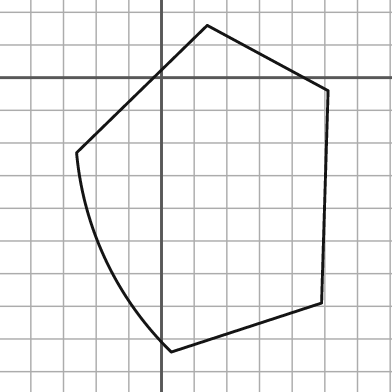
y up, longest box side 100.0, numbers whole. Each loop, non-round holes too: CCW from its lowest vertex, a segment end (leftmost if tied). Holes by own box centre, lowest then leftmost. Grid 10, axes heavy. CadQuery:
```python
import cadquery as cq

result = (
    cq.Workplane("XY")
    .moveTo(3.0, -84.0)
    .lineTo(49.0, -69.0)
    .lineTo(51.0, -4.0)
    .lineTo(14.0, 16.0)
    .lineTo(-26.0, -23.0)
    .threePointArc((-17.0, -56.0), (3.0, -84.0))
    .close()
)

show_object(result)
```